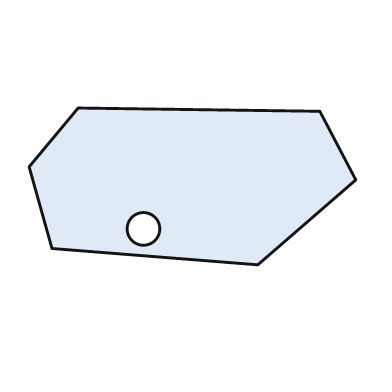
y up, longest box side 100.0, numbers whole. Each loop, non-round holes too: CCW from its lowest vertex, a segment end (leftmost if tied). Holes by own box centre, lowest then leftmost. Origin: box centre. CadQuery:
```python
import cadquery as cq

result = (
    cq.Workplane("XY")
    .moveTo(20.0, -24.0)
    .lineTo(50.0, 2.0)
    .lineTo(39.0, 23.0)
    .lineTo(-35.0, 24.0)
    .lineTo(-50.0, 6.0)
    .lineTo(-43.0, -19.0)
    .close()
    .moveTo(-15.0, -13.0)
    .circle(5.0)
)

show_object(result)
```